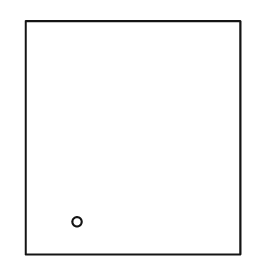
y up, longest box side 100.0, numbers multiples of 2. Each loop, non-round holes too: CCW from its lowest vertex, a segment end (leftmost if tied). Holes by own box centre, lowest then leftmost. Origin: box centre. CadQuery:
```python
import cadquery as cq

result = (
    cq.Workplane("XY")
    .moveTo(-46.0, -50.0)
    .lineTo(46.0, -50.0)
    .lineTo(46.0, 50.0)
    .lineTo(-46.0, 50.0)
    .close()
    .moveTo(-24.0, -36.0)
    .circle(2.0)
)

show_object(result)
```